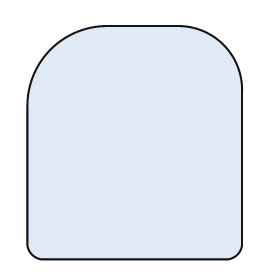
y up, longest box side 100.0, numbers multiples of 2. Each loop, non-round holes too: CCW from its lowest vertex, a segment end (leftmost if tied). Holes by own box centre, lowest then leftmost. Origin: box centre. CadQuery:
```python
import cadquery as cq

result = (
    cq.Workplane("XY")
    .moveTo(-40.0, -50.0)
    .lineTo(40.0, -50.0)
    .threePointArc((44.0, -48.0), (46.0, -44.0))
    .lineTo(46.0, 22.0)
    .threePointArc((38.0, 42.0), (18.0, 50.0))
    .lineTo(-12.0, 50.0)
    .threePointArc((-36.0, 40.0), (-46.0, 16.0))
    .lineTo(-46.0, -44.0)
    .threePointArc((-44.0, -48.0), (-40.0, -50.0))
    .close()
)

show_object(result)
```